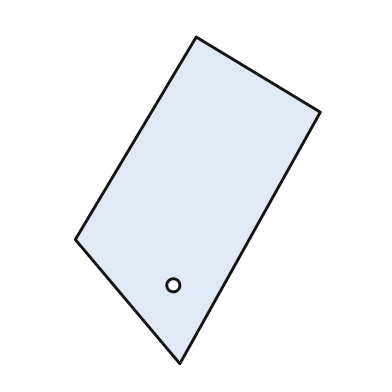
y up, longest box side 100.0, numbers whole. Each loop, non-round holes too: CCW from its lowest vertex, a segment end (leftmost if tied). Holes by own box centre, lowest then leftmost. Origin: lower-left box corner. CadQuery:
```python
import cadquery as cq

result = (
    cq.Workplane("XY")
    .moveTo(32.0, 0.0)
    .lineTo(75.0, 77.0)
    .lineTo(37.0, 100.0)
    .lineTo(0.0, 38.0)
    .close()
    .moveTo(30.0, 24.0)
    .circle(2.0)
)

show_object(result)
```